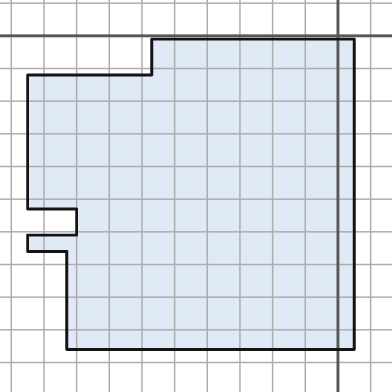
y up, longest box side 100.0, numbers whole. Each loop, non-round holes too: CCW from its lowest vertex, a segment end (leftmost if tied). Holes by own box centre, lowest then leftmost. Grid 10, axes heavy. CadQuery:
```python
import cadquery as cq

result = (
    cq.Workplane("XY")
    .moveTo(-83.0, -96.0)
    .lineTo(5.0, -96.0)
    .lineTo(5.0, -1.0)
    .lineTo(-57.0, -1.0)
    .lineTo(-57.0, -12.0)
    .lineTo(-95.0, -12.0)
    .lineTo(-95.0, -53.0)
    .lineTo(-80.0, -53.0)
    .lineTo(-80.0, -61.0)
    .lineTo(-95.0, -61.0)
    .lineTo(-95.0, -66.0)
    .lineTo(-83.0, -66.0)
    .close()
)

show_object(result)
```